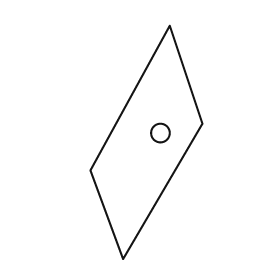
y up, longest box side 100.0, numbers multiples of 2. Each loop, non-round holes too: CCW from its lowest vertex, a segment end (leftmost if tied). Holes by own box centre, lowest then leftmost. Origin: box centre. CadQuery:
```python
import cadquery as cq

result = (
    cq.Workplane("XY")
    .moveTo(-10.0, -50.0)
    .lineTo(24.0, 8.0)
    .lineTo(10.0, 50.0)
    .lineTo(-24.0, -12.0)
    .close()
    .moveTo(6.0, 4.0)
    .circle(4.0)
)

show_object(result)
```